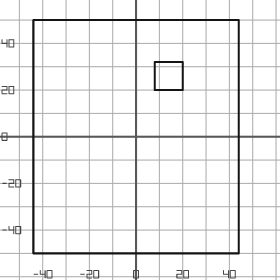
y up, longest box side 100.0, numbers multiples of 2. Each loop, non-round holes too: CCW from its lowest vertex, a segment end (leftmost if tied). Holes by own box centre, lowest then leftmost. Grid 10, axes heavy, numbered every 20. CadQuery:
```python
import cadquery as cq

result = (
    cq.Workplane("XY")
    .moveTo(-44.0, -50.0)
    .lineTo(44.0, -50.0)
    .lineTo(44.0, 50.0)
    .lineTo(-44.0, 50.0)
    .close()
    .moveTo(8.0, 20.0)
    .lineTo(20.0, 20.0)
    .lineTo(20.0, 32.0)
    .lineTo(8.0, 32.0)
    .close()
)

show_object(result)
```